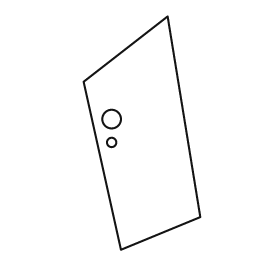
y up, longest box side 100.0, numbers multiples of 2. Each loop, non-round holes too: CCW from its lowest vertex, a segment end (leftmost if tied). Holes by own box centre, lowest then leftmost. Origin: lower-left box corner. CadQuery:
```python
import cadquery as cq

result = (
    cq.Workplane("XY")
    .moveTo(16.0, 0.0)
    .lineTo(50.0, 14.0)
    .lineTo(36.0, 100.0)
    .lineTo(0.0, 72.0)
    .close()
    .moveTo(12.0, 46.0)
    .circle(2.0)
    .moveTo(12.0, 56.0)
    .circle(4.0)
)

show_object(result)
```